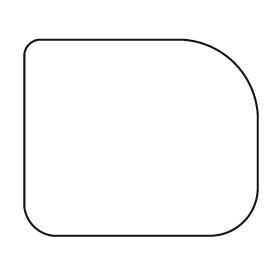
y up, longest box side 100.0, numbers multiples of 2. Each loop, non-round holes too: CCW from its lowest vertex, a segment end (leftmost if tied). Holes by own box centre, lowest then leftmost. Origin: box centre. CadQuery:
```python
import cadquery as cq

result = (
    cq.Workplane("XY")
    .moveTo(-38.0, -42.0)
    .lineTo(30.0, -42.0)
    .threePointArc((44.0, -36.0), (50.0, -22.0))
    .lineTo(50.0, 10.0)
    .threePointArc((40.0, 32.0), (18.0, 42.0))
    .lineTo(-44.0, 42.0)
    .threePointArc((-48.0, 40.0), (-50.0, 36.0))
    .lineTo(-50.0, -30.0)
    .threePointArc((-46.0, -38.0), (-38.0, -42.0))
    .close()
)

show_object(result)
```